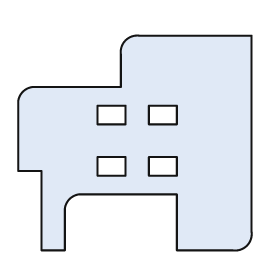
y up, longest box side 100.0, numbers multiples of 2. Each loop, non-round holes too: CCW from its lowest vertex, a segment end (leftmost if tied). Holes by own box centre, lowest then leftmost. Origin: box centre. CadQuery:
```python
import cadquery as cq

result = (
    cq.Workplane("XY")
    .moveTo(-40.0, -46.0)
    .lineTo(-30.0, -46.0)
    .lineTo(-30.0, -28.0)
    .threePointArc((-28.0, -24.0), (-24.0, -22.0))
    .lineTo(18.0, -22.0)
    .lineTo(18.0, -46.0)
    .lineTo(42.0, -46.0)
    .threePointArc((48.0, -44.0), (50.0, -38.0))
    .lineTo(50.0, 46.0)
    .lineTo(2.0, 46.0)
    .threePointArc((-4.0, 44.0), (-6.0, 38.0))
    .lineTo(-6.0, 24.0)
    .lineTo(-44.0, 24.0)
    .threePointArc((-48.0, 22.0), (-50.0, 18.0))
    .lineTo(-50.0, -12.0)
    .lineTo(-40.0, -12.0)
    .close()
    .moveTo(-16.0, -14.0)
    .lineTo(-4.0, -14.0)
    .lineTo(-4.0, -6.0)
    .lineTo(-16.0, -6.0)
    .close()
    .moveTo(6.0, -14.0)
    .lineTo(18.0, -14.0)
    .lineTo(18.0, -6.0)
    .lineTo(6.0, -6.0)
    .close()
    .moveTo(-16.0, 8.0)
    .lineTo(-4.0, 8.0)
    .lineTo(-4.0, 16.0)
    .lineTo(-16.0, 16.0)
    .close()
    .moveTo(6.0, 8.0)
    .lineTo(18.0, 8.0)
    .lineTo(18.0, 16.0)
    .lineTo(6.0, 16.0)
    .close()
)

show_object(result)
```